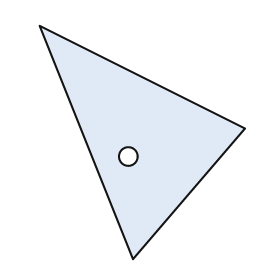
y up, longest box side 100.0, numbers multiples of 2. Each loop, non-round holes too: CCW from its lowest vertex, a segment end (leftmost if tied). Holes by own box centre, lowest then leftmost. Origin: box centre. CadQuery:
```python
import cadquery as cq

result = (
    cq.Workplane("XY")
    .moveTo(-4.0, -50.0)
    .lineTo(44.0, 6.0)
    .lineTo(-44.0, 50.0)
    .close()
    .moveTo(-6.0, -6.0)
    .circle(4.0)
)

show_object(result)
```